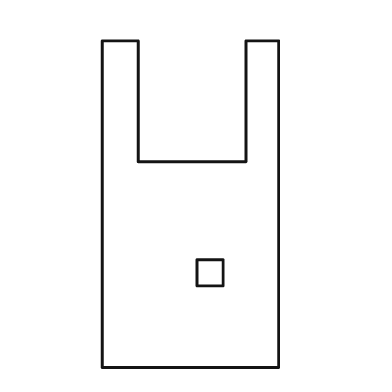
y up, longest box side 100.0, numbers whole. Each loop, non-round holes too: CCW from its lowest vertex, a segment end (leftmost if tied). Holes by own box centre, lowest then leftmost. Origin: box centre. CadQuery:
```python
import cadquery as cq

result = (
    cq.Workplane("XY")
    .moveTo(-27.0, -50.0)
    .lineTo(27.0, -50.0)
    .lineTo(27.0, 50.0)
    .lineTo(17.0, 50.0)
    .lineTo(17.0, 13.0)
    .lineTo(-16.0, 13.0)
    .lineTo(-16.0, 50.0)
    .lineTo(-27.0, 50.0)
    .close()
    .moveTo(2.0, -25.0)
    .lineTo(10.0, -25.0)
    .lineTo(10.0, -17.0)
    .lineTo(2.0, -17.0)
    .close()
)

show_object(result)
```